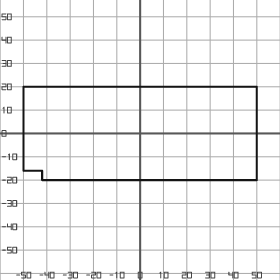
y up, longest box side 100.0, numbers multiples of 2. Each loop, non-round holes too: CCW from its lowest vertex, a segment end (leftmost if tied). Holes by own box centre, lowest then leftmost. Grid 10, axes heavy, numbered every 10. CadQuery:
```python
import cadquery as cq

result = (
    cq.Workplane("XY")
    .moveTo(-42.0, -20.0)
    .lineTo(50.0, -20.0)
    .lineTo(50.0, 20.0)
    .lineTo(-50.0, 20.0)
    .lineTo(-50.0, -16.0)
    .lineTo(-42.0, -16.0)
    .close()
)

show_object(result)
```